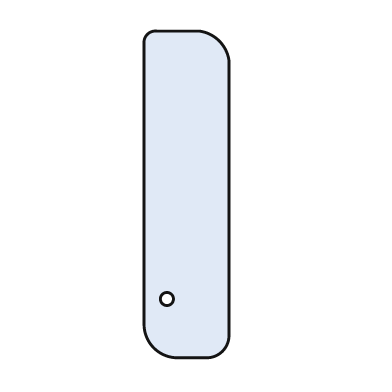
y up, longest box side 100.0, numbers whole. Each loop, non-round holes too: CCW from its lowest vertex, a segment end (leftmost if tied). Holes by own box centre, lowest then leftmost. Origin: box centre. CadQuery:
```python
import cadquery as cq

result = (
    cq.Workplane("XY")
    .moveTo(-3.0, -50.0)
    .lineTo(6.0, -50.0)
    .threePointArc((11.0, -48.0), (13.0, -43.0))
    .lineTo(13.0, 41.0)
    .threePointArc((10.0, 47.0), (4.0, 50.0))
    .lineTo(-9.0, 50.0)
    .threePointArc((-12.0, 49.0), (-13.0, 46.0))
    .lineTo(-13.0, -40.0)
    .threePointArc((-10.0, -47.0), (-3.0, -50.0))
    .close()
    .moveTo(-6.0, -32.0)
    .circle(2.0)
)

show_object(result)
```